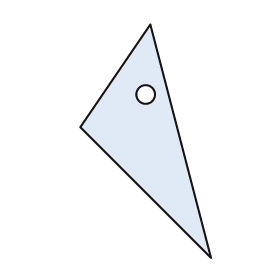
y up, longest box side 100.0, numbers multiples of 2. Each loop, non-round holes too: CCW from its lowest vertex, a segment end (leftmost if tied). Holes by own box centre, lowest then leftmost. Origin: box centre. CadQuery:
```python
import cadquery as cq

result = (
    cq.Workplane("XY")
    .moveTo(28.0, -50.0)
    .lineTo(2.0, 50.0)
    .lineTo(-28.0, 6.0)
    .close()
    .moveTo(0.0, 20.0)
    .circle(4.0)
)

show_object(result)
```